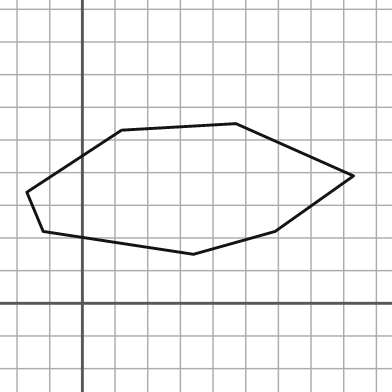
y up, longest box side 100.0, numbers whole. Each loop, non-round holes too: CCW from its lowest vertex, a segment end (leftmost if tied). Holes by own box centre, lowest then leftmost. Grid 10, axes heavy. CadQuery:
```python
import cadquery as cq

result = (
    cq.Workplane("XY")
    .moveTo(34.0, 15.0)
    .lineTo(59.0, 22.0)
    .lineTo(83.0, 39.0)
    .lineTo(47.0, 55.0)
    .lineTo(12.0, 53.0)
    .lineTo(-17.0, 34.0)
    .lineTo(-12.0, 22.0)
    .close()
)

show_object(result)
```